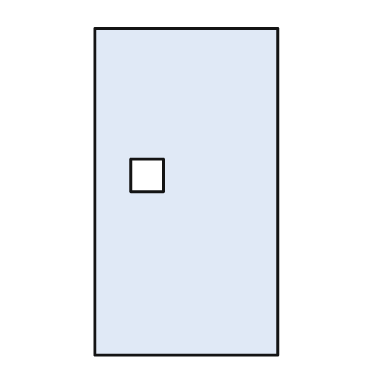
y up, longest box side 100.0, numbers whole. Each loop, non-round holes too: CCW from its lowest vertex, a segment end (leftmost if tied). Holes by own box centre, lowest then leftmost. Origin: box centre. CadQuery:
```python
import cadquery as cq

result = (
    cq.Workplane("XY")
    .moveTo(-28.0, -50.0)
    .lineTo(28.0, -50.0)
    .lineTo(28.0, 50.0)
    .lineTo(-28.0, 50.0)
    .close()
    .moveTo(-17.0, 0.0)
    .lineTo(-7.0, 0.0)
    .lineTo(-7.0, 10.0)
    .lineTo(-17.0, 10.0)
    .close()
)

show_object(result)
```